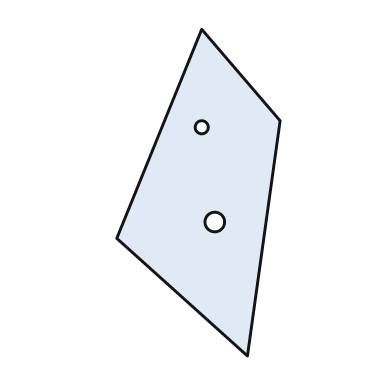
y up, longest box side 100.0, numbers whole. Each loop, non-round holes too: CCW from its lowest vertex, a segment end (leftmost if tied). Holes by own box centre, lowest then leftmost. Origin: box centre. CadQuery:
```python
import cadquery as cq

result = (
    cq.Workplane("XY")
    .moveTo(15.0, -50.0)
    .lineTo(25.0, 22.0)
    .lineTo(1.0, 50.0)
    .lineTo(-25.0, -14.0)
    .close()
    .moveTo(5.0, -9.0)
    .circle(3.0)
    .moveTo(1.0, 20.0)
    .circle(2.0)
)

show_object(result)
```